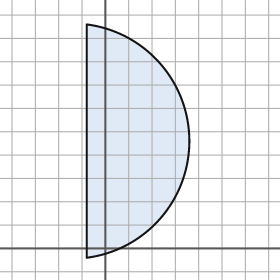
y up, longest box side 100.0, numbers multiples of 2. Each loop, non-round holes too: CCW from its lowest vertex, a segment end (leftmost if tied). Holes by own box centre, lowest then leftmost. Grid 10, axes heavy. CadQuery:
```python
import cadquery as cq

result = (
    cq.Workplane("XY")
    .moveTo(-8.0, -4.0)
    .threePointArc((36.0, 46.0), (-8.0, 96.0))
    .close()
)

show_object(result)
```